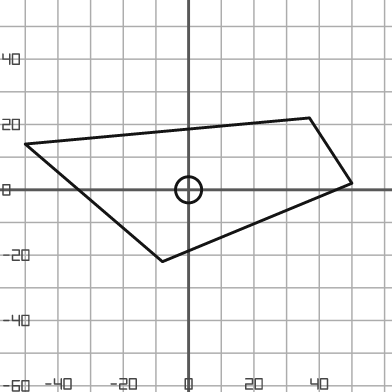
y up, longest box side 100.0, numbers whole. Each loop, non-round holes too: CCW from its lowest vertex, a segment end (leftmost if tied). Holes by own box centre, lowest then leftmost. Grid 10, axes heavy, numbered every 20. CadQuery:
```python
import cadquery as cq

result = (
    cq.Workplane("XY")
    .moveTo(-8.0, -22.0)
    .lineTo(50.0, 2.0)
    .lineTo(37.0, 22.0)
    .lineTo(-50.0, 14.0)
    .close()
    .moveTo(0.0, 0.0)
    .circle(4.0)
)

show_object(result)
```